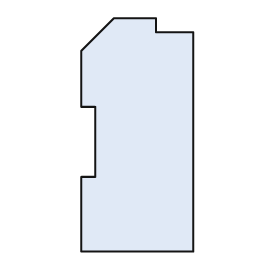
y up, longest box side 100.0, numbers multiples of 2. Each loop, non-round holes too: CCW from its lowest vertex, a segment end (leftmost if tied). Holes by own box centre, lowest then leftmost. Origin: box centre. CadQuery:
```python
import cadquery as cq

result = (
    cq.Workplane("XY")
    .moveTo(-24.0, -50.0)
    .lineTo(24.0, -50.0)
    .lineTo(24.0, 44.0)
    .lineTo(8.0, 44.0)
    .lineTo(8.0, 50.0)
    .lineTo(-10.0, 50.0)
    .lineTo(-24.0, 36.0)
    .lineTo(-24.0, 12.0)
    .lineTo(-18.0, 12.0)
    .lineTo(-18.0, -18.0)
    .lineTo(-24.0, -18.0)
    .close()
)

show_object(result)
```